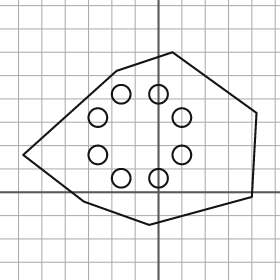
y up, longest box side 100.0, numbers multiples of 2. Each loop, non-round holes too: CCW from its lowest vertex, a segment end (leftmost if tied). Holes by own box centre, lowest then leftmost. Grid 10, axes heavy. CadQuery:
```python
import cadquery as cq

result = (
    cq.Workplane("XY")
    .moveTo(-4.0, -14.0)
    .lineTo(40.0, -2.0)
    .lineTo(42.0, 34.0)
    .lineTo(6.0, 60.0)
    .lineTo(-18.0, 52.0)
    .lineTo(-58.0, 16.0)
    .lineTo(-32.0, -4.0)
    .close()
    .moveTo(-16.0, 6.0)
    .circle(4.0)
    .moveTo(0.0, 6.0)
    .circle(4.0)
    .moveTo(-26.0, 16.0)
    .circle(4.0)
    .moveTo(10.0, 16.0)
    .circle(4.0)
    .moveTo(-26.0, 32.0)
    .circle(4.0)
    .moveTo(10.0, 32.0)
    .circle(4.0)
    .moveTo(-16.0, 42.0)
    .circle(4.0)
    .moveTo(0.0, 42.0)
    .circle(4.0)
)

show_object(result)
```